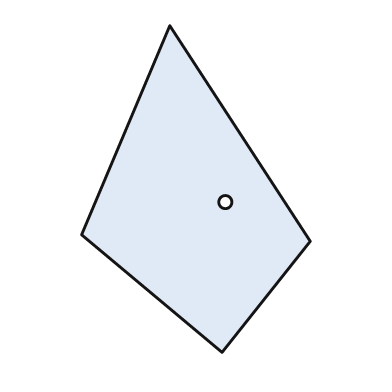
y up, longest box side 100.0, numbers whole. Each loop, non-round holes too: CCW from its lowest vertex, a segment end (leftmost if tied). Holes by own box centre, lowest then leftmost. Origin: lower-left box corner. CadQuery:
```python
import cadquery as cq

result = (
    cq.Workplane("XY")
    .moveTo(43.0, 0.0)
    .lineTo(70.0, 34.0)
    .lineTo(27.0, 100.0)
    .lineTo(0.0, 36.0)
    .close()
    .moveTo(44.0, 46.0)
    .circle(2.0)
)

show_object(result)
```